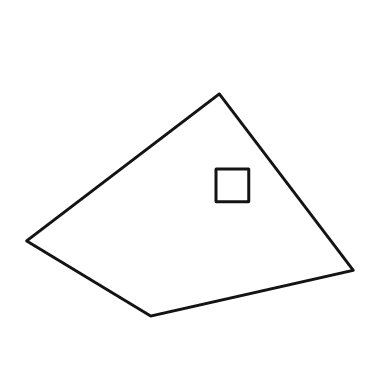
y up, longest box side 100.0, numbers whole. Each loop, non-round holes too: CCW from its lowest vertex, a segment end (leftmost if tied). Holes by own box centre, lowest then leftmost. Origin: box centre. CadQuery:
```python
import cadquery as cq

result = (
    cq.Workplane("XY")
    .moveTo(-12.0, -34.0)
    .lineTo(50.0, -20.0)
    .lineTo(9.0, 34.0)
    .lineTo(-50.0, -11.0)
    .close()
    .moveTo(8.0, 1.0)
    .lineTo(18.0, 1.0)
    .lineTo(18.0, 11.0)
    .lineTo(8.0, 11.0)
    .close()
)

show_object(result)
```